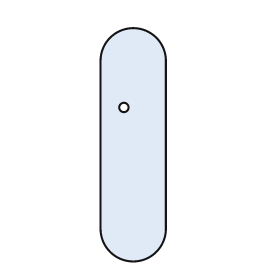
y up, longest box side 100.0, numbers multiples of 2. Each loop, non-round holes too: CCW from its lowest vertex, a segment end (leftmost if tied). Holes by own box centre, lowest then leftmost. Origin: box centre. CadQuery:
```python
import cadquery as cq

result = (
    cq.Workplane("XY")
    .moveTo(-14.0, -36.0)
    .threePointArc((0.0, -50.0), (14.0, -36.0))
    .lineTo(14.0, 36.0)
    .threePointArc((0.0, 50.0), (-14.0, 36.0))
    .close()
    .moveTo(-4.0, 16.0)
    .circle(2.0)
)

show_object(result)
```